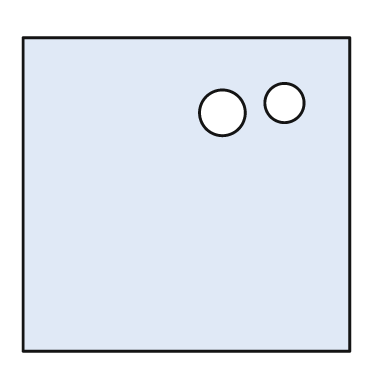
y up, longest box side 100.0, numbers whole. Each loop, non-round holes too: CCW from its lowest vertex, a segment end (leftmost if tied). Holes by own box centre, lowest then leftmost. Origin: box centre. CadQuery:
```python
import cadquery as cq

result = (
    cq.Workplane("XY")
    .moveTo(-50.0, -48.0)
    .lineTo(50.0, -48.0)
    .lineTo(50.0, 48.0)
    .lineTo(-50.0, 48.0)
    .close()
    .moveTo(11.0, 25.0)
    .circle(7.0)
    .moveTo(30.0, 28.0)
    .circle(6.0)
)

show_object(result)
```